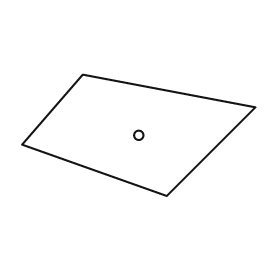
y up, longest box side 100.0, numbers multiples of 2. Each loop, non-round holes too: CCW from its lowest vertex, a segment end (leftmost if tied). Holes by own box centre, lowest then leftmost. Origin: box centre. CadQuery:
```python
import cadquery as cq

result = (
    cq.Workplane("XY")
    .moveTo(12.0, -26.0)
    .lineTo(50.0, 12.0)
    .lineTo(-24.0, 26.0)
    .lineTo(-50.0, -4.0)
    .close()
    .moveTo(0.0, 0.0)
    .circle(2.0)
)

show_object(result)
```